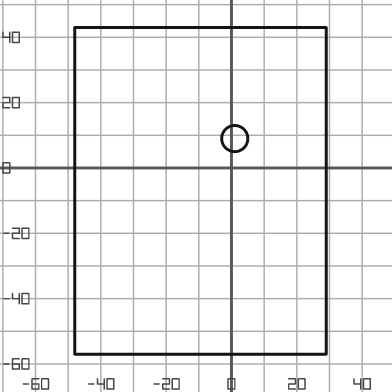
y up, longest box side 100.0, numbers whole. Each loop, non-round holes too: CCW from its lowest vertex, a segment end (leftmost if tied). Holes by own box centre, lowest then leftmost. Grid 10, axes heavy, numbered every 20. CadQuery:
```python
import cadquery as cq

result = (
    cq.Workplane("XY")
    .moveTo(-48.0, -57.0)
    .lineTo(29.0, -57.0)
    .lineTo(29.0, 43.0)
    .lineTo(-48.0, 43.0)
    .close()
    .moveTo(1.0, 9.0)
    .circle(4.0)
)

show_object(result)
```